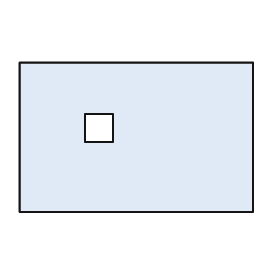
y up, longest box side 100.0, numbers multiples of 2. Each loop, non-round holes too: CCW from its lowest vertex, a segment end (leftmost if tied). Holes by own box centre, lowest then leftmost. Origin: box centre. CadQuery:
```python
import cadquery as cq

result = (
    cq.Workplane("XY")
    .moveTo(-50.0, -32.0)
    .lineTo(50.0, -32.0)
    .lineTo(50.0, 32.0)
    .lineTo(-50.0, 32.0)
    .close()
    .moveTo(-22.0, -2.0)
    .lineTo(-10.0, -2.0)
    .lineTo(-10.0, 10.0)
    .lineTo(-22.0, 10.0)
    .close()
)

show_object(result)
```